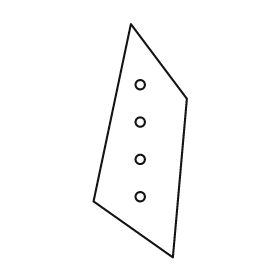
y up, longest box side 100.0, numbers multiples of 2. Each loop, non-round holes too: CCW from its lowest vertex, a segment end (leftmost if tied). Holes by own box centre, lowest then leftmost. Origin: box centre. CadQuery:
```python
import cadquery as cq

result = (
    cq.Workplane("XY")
    .moveTo(14.0, -50.0)
    .lineTo(20.0, 18.0)
    .lineTo(-4.0, 50.0)
    .lineTo(-20.0, -26.0)
    .close()
    .moveTo(0.0, -24.0)
    .circle(2.0)
    .moveTo(0.0, -8.0)
    .circle(2.0)
    .moveTo(0.0, 8.0)
    .circle(2.0)
    .moveTo(0.0, 24.0)
    .circle(2.0)
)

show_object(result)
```